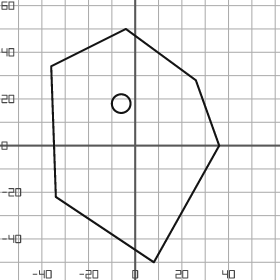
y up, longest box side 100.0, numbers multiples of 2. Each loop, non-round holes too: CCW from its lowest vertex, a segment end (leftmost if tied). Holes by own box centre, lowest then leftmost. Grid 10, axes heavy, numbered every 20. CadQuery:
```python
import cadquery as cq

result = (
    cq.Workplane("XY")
    .moveTo(8.0, -50.0)
    .lineTo(36.0, 0.0)
    .lineTo(26.0, 28.0)
    .lineTo(-4.0, 50.0)
    .lineTo(-36.0, 34.0)
    .lineTo(-34.0, -22.0)
    .close()
    .moveTo(-6.0, 18.0)
    .circle(4.0)
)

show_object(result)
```